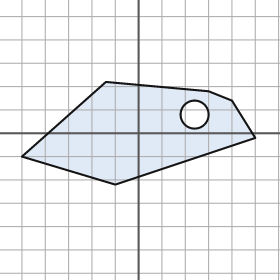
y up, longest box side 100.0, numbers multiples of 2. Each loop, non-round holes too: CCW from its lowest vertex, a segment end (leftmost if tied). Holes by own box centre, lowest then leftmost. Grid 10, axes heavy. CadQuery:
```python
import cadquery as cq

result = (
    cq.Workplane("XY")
    .moveTo(-10.0, -22.0)
    .lineTo(50.0, -2.0)
    .lineTo(40.0, 14.0)
    .lineTo(30.0, 18.0)
    .lineTo(-14.0, 22.0)
    .lineTo(-50.0, -10.0)
    .close()
    .moveTo(24.0, 8.0)
    .circle(6.0)
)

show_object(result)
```